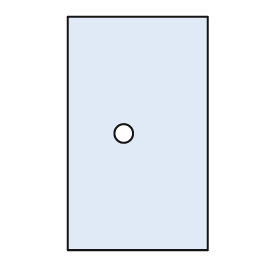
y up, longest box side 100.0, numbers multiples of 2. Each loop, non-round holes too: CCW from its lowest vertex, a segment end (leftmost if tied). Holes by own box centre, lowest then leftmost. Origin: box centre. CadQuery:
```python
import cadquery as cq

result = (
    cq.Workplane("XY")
    .moveTo(-30.0, -50.0)
    .lineTo(30.0, -50.0)
    .lineTo(30.0, 50.0)
    .lineTo(-30.0, 50.0)
    .close()
    .moveTo(-6.0, 0.0)
    .circle(4.0)
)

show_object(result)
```